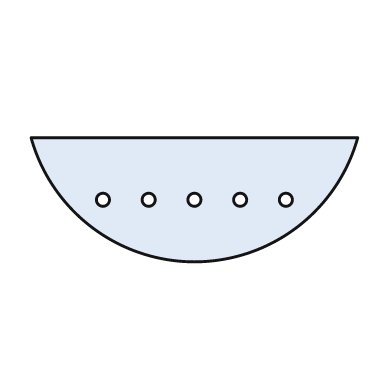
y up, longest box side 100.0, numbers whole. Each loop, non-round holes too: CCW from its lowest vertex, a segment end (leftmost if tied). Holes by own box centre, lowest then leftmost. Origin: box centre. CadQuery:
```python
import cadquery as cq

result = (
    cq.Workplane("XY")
    .moveTo(-50.0, 19.0)
    .threePointArc((0.0, -19.0), (50.0, 19.0))
    .close()
    .moveTo(-28.0, 0.0)
    .circle(2.0)
    .moveTo(-14.0, 0.0)
    .circle(2.0)
    .moveTo(0.0, 0.0)
    .circle(2.0)
    .moveTo(14.0, 0.0)
    .circle(2.0)
    .moveTo(28.0, 0.0)
    .circle(2.0)
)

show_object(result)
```